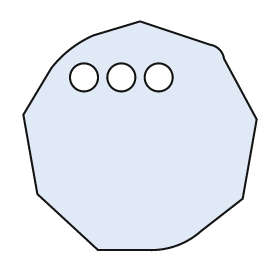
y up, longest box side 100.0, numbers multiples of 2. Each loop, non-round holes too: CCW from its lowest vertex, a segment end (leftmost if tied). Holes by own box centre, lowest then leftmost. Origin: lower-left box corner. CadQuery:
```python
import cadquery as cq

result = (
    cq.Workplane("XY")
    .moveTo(32.0, 0.0)
    .lineTo(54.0, 0.0)
    .threePointArc((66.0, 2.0), (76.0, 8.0))
    .lineTo(94.0, 22.0)
    .lineTo(100.0, 56.0)
    .lineTo(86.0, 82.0)
    .threePointArc((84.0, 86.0), (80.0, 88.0))
    .lineTo(50.0, 98.0)
    .lineTo(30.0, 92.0)
    .threePointArc((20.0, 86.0), (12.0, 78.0))
    .lineTo(0.0, 58.0)
    .lineTo(6.0, 24.0)
    .close()
    .moveTo(26.0, 74.0)
    .circle(6.0)
    .moveTo(42.0, 74.0)
    .circle(6.0)
    .moveTo(58.0, 74.0)
    .circle(6.0)
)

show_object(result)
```